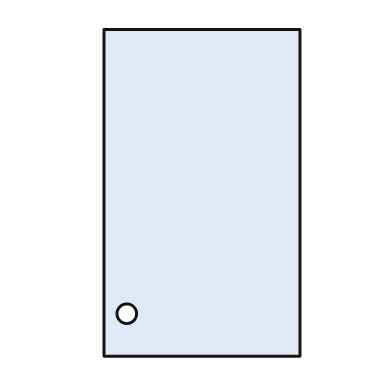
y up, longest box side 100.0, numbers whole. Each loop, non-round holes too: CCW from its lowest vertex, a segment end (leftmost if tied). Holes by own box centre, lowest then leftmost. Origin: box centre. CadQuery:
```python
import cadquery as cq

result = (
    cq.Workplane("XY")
    .moveTo(-30.0, -50.0)
    .lineTo(30.0, -50.0)
    .lineTo(30.0, 50.0)
    .lineTo(-30.0, 50.0)
    .close()
    .moveTo(-23.0, -37.0)
    .circle(3.0)
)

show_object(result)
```